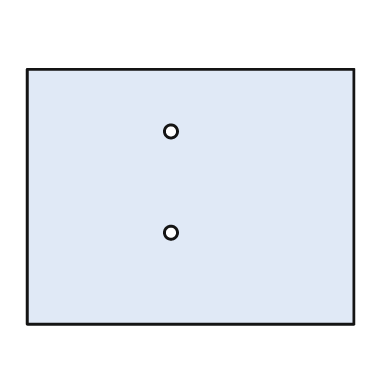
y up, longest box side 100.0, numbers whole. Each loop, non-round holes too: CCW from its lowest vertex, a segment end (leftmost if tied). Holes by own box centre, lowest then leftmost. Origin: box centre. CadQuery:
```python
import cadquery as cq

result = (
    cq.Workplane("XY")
    .moveTo(-50.0, -39.0)
    .lineTo(50.0, -39.0)
    .lineTo(50.0, 39.0)
    .lineTo(-50.0, 39.0)
    .close()
    .moveTo(-6.0, -11.0)
    .circle(2.0)
    .moveTo(-6.0, 20.0)
    .circle(2.0)
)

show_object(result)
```